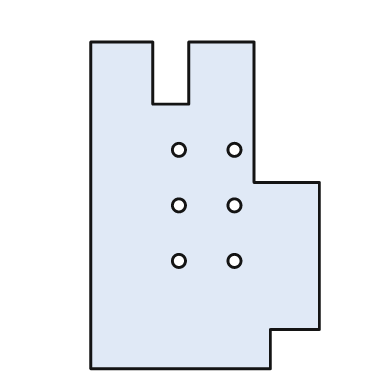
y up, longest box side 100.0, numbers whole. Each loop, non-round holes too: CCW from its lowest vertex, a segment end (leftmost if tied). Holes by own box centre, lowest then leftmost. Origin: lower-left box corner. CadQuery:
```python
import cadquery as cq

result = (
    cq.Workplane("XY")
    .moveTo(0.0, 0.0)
    .lineTo(55.0, 0.0)
    .lineTo(55.0, 12.0)
    .lineTo(70.0, 12.0)
    .lineTo(70.0, 57.0)
    .lineTo(50.0, 57.0)
    .lineTo(50.0, 100.0)
    .lineTo(30.0, 100.0)
    .lineTo(30.0, 81.0)
    .lineTo(19.0, 81.0)
    .lineTo(19.0, 100.0)
    .lineTo(0.0, 100.0)
    .close()
    .moveTo(27.0, 33.0)
    .circle(2.0)
    .moveTo(44.0, 33.0)
    .circle(2.0)
    .moveTo(27.0, 50.0)
    .circle(2.0)
    .moveTo(44.0, 50.0)
    .circle(2.0)
    .moveTo(27.0, 67.0)
    .circle(2.0)
    .moveTo(44.0, 67.0)
    .circle(2.0)
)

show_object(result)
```